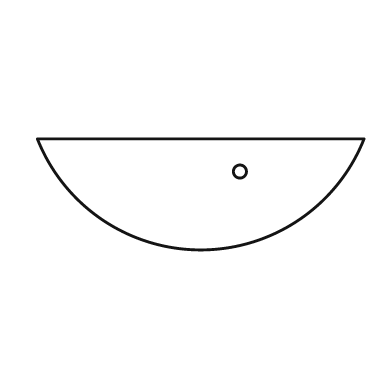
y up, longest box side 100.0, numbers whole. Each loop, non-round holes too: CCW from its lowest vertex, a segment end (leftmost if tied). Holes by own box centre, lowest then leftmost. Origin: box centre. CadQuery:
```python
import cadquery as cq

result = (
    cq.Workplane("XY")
    .moveTo(-50.0, 17.0)
    .threePointArc((0.0, -17.0), (50.0, 17.0))
    .close()
    .moveTo(12.0, 7.0)
    .circle(2.0)
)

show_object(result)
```